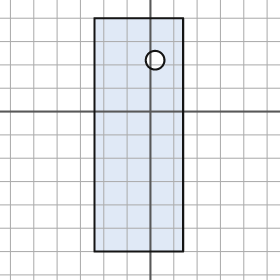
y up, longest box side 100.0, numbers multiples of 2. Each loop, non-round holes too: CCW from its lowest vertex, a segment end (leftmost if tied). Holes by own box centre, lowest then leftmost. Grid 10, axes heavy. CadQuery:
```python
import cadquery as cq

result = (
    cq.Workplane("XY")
    .moveTo(-24.0, -60.0)
    .lineTo(14.0, -60.0)
    .lineTo(14.0, 40.0)
    .lineTo(-24.0, 40.0)
    .close()
    .moveTo(2.0, 22.0)
    .circle(4.0)
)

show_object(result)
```